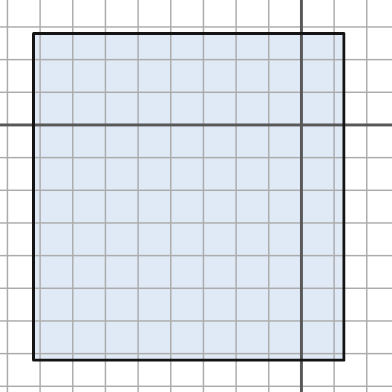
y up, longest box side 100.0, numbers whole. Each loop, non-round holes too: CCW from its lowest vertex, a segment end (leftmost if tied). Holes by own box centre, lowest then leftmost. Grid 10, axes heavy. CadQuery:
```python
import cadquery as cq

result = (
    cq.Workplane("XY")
    .moveTo(-82.0, -72.0)
    .lineTo(13.0, -72.0)
    .lineTo(13.0, 28.0)
    .lineTo(-82.0, 28.0)
    .close()
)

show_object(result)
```